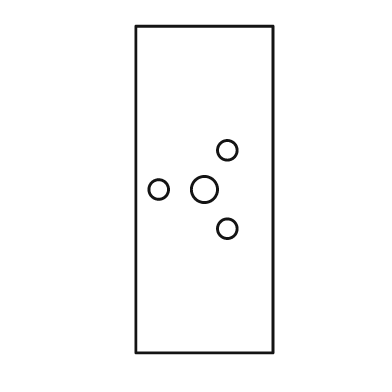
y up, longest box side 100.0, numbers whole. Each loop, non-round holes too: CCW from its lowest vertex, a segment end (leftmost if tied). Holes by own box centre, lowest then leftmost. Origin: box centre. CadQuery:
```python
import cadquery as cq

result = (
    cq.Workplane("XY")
    .moveTo(-21.0, -50.0)
    .lineTo(21.0, -50.0)
    .lineTo(21.0, 50.0)
    .lineTo(-21.0, 50.0)
    .close()
    .moveTo(7.0, -12.0)
    .circle(3.0)
    .moveTo(-14.0, 0.0)
    .circle(3.0)
    .moveTo(0.0, 0.0)
    .circle(4.0)
    .moveTo(7.0, 12.0)
    .circle(3.0)
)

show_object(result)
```